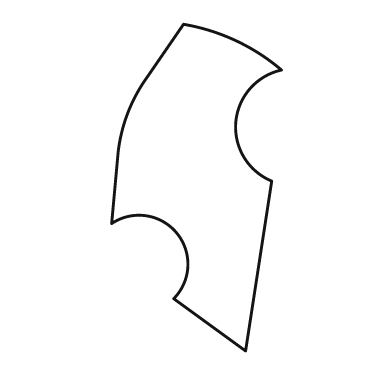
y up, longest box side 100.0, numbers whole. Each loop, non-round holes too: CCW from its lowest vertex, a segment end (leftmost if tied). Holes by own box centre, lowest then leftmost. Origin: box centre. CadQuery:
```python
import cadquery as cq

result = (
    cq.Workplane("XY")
    .moveTo(15.0, -50.0)
    .lineTo(23.0, 2.0)
    .threePointArc((12.0, 20.0), (26.0, 36.0))
    .threePointArc((12.0, 45.0), (-4.0, 50.0))
    .lineTo(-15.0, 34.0)
    .threePointArc((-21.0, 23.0), (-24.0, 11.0))
    .lineTo(-26.0, -11.0)
    .threePointArc((-6.0, -14.0), (-7.0, -34.0))
    .close()
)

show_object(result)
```